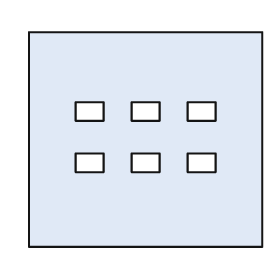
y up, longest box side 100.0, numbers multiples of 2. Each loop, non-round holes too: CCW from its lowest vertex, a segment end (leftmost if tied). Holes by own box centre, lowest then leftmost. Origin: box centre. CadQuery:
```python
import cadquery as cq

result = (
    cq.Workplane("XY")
    .moveTo(-50.0, -46.0)
    .lineTo(50.0, -46.0)
    .lineTo(50.0, 46.0)
    .lineTo(-50.0, 46.0)
    .close()
    .moveTo(-30.0, -14.0)
    .lineTo(-18.0, -14.0)
    .lineTo(-18.0, -6.0)
    .lineTo(-30.0, -6.0)
    .close()
    .moveTo(-6.0, -14.0)
    .lineTo(6.0, -14.0)
    .lineTo(6.0, -6.0)
    .lineTo(-6.0, -6.0)
    .close()
    .moveTo(18.0, -14.0)
    .lineTo(30.0, -14.0)
    .lineTo(30.0, -6.0)
    .lineTo(18.0, -6.0)
    .close()
    .moveTo(-30.0, 8.0)
    .lineTo(-18.0, 8.0)
    .lineTo(-18.0, 16.0)
    .lineTo(-30.0, 16.0)
    .close()
    .moveTo(-6.0, 8.0)
    .lineTo(6.0, 8.0)
    .lineTo(6.0, 16.0)
    .lineTo(-6.0, 16.0)
    .close()
    .moveTo(18.0, 8.0)
    .lineTo(30.0, 8.0)
    .lineTo(30.0, 16.0)
    .lineTo(18.0, 16.0)
    .close()
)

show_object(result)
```